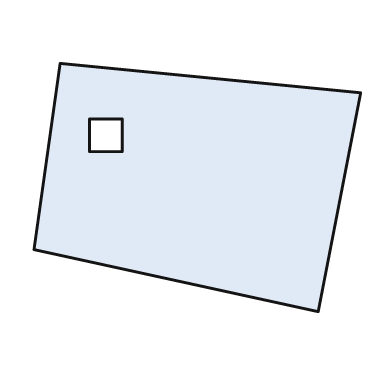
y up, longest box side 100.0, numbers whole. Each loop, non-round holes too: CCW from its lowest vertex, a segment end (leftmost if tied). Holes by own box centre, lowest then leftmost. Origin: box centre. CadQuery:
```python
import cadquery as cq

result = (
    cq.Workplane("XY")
    .moveTo(37.0, -38.0)
    .lineTo(50.0, 29.0)
    .lineTo(-42.0, 38.0)
    .lineTo(-50.0, -19.0)
    .close()
    .moveTo(-33.0, 11.0)
    .lineTo(-23.0, 11.0)
    .lineTo(-23.0, 21.0)
    .lineTo(-33.0, 21.0)
    .close()
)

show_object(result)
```